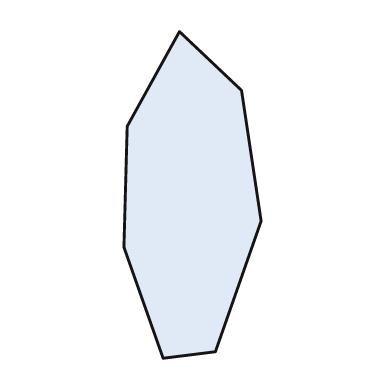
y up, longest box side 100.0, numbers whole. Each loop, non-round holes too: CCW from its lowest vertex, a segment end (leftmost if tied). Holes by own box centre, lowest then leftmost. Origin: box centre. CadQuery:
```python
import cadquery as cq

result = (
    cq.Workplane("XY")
    .moveTo(-9.0, -50.0)
    .lineTo(7.0, -48.0)
    .lineTo(21.0, -8.0)
    .lineTo(15.0, 32.0)
    .lineTo(-4.0, 50.0)
    .lineTo(-20.0, 21.0)
    .lineTo(-21.0, -16.0)
    .close()
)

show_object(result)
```